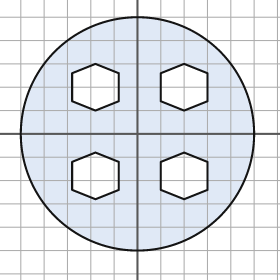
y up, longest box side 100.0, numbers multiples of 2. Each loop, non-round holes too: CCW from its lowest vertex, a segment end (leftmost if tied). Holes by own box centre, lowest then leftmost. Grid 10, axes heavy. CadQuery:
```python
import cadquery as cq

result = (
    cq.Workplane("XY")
    .moveTo(0.0, 0.0)
    .circle(50.0)
    .moveTo(-18.0, -28.0)
    .lineTo(-8.0, -24.0)
    .lineTo(-8.0, -12.0)
    .lineTo(-18.0, -8.0)
    .lineTo(-28.0, -12.0)
    .lineTo(-28.0, -24.0)
    .close()
    .moveTo(20.0, -28.0)
    .lineTo(30.0, -24.0)
    .lineTo(30.0, -12.0)
    .lineTo(20.0, -8.0)
    .lineTo(10.0, -12.0)
    .lineTo(10.0, -24.0)
    .close()
    .moveTo(-18.0, 10.0)
    .lineTo(-8.0, 14.0)
    .lineTo(-8.0, 26.0)
    .lineTo(-18.0, 30.0)
    .lineTo(-28.0, 26.0)
    .lineTo(-28.0, 14.0)
    .close()
    .moveTo(20.0, 10.0)
    .lineTo(30.0, 14.0)
    .lineTo(30.0, 26.0)
    .lineTo(20.0, 30.0)
    .lineTo(10.0, 26.0)
    .lineTo(10.0, 14.0)
    .close()
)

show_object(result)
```